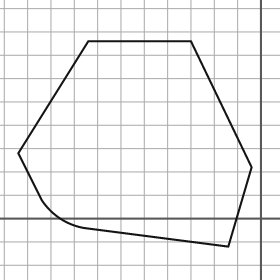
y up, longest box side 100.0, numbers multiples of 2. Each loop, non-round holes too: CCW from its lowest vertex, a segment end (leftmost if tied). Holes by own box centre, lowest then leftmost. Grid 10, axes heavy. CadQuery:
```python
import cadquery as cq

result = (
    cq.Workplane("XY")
    .moveTo(-14.0, -12.0)
    .lineTo(-4.0, 22.0)
    .lineTo(-30.0, 76.0)
    .lineTo(-74.0, 76.0)
    .lineTo(-104.0, 28.0)
    .lineTo(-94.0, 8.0)
    .threePointArc((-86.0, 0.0), (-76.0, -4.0))
    .close()
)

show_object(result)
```